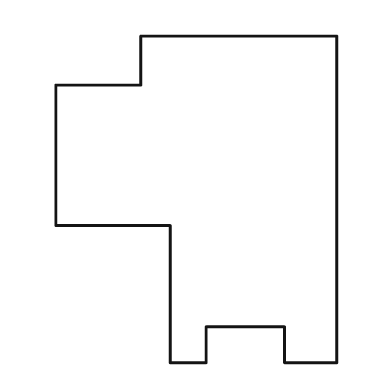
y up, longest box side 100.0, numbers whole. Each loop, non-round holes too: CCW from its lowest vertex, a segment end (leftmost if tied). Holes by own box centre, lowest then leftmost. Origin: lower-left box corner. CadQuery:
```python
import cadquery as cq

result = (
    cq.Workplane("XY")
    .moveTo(35.0, 0.0)
    .lineTo(46.0, 0.0)
    .lineTo(46.0, 11.0)
    .lineTo(70.0, 11.0)
    .lineTo(70.0, 0.0)
    .lineTo(86.0, 0.0)
    .lineTo(86.0, 100.0)
    .lineTo(26.0, 100.0)
    .lineTo(26.0, 85.0)
    .lineTo(0.0, 85.0)
    .lineTo(0.0, 42.0)
    .lineTo(35.0, 42.0)
    .close()
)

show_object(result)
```